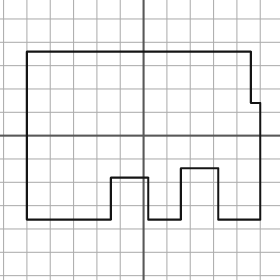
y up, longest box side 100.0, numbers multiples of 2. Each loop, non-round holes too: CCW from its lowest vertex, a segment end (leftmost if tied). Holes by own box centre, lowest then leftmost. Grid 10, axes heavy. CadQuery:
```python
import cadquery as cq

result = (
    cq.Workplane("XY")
    .moveTo(-50.0, -36.0)
    .lineTo(-14.0, -36.0)
    .lineTo(-14.0, -18.0)
    .lineTo(2.0, -18.0)
    .lineTo(2.0, -36.0)
    .lineTo(16.0, -36.0)
    .lineTo(16.0, -14.0)
    .lineTo(32.0, -14.0)
    .lineTo(32.0, -36.0)
    .lineTo(50.0, -36.0)
    .lineTo(50.0, 14.0)
    .lineTo(46.0, 14.0)
    .lineTo(46.0, 36.0)
    .lineTo(-50.0, 36.0)
    .close()
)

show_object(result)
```